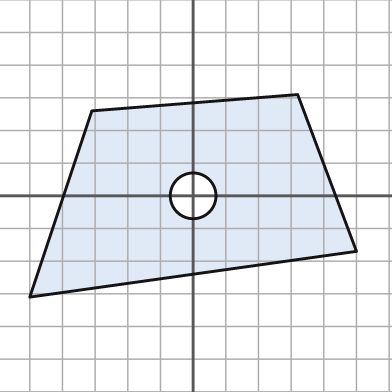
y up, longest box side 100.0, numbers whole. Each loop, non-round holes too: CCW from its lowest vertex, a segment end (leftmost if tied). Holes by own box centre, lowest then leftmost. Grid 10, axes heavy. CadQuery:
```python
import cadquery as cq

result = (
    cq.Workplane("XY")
    .moveTo(-50.0, -31.0)
    .lineTo(50.0, -17.0)
    .lineTo(32.0, 31.0)
    .lineTo(-31.0, 26.0)
    .close()
    .moveTo(0.0, 0.0)
    .circle(7.0)
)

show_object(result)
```